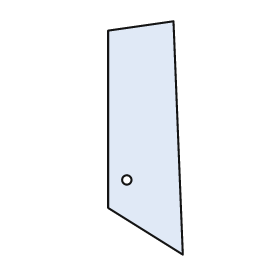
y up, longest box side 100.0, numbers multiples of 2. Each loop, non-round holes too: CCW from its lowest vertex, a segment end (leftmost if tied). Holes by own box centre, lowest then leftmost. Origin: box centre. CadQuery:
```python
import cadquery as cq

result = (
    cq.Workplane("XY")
    .moveTo(16.0, -50.0)
    .lineTo(12.0, 50.0)
    .lineTo(-16.0, 46.0)
    .lineTo(-16.0, -30.0)
    .close()
    .moveTo(-8.0, -18.0)
    .circle(2.0)
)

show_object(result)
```